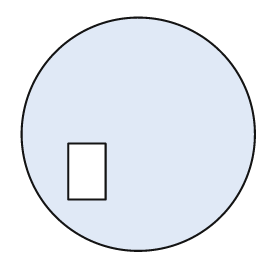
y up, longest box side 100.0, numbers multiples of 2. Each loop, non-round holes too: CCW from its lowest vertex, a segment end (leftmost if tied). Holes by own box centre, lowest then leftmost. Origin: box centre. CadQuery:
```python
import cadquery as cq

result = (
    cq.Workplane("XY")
    .moveTo(0.0, 0.0)
    .circle(50.0)
    .moveTo(-30.0, -28.0)
    .lineTo(-14.0, -28.0)
    .lineTo(-14.0, -4.0)
    .lineTo(-30.0, -4.0)
    .close()
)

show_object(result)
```